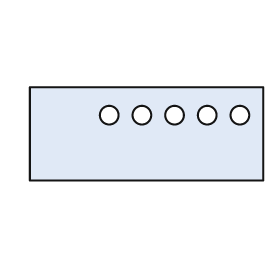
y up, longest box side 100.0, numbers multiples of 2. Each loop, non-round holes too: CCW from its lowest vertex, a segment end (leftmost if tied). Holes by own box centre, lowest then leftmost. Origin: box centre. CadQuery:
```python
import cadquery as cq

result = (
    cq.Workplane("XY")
    .moveTo(-50.0, -20.0)
    .lineTo(50.0, -20.0)
    .lineTo(50.0, 20.0)
    .lineTo(-50.0, 20.0)
    .close()
    .moveTo(-16.0, 8.0)
    .circle(4.0)
    .moveTo(-2.0, 8.0)
    .circle(4.0)
    .moveTo(12.0, 8.0)
    .circle(4.0)
    .moveTo(26.0, 8.0)
    .circle(4.0)
    .moveTo(40.0, 8.0)
    .circle(4.0)
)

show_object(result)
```